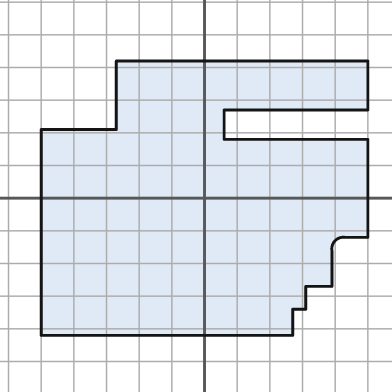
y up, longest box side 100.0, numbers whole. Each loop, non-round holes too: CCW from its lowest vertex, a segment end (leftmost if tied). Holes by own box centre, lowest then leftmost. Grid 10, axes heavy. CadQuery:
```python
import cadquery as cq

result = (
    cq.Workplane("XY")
    .moveTo(-50.0, -42.0)
    .lineTo(27.0, -42.0)
    .lineTo(27.0, -34.0)
    .lineTo(31.0, -34.0)
    .lineTo(31.0, -27.0)
    .lineTo(39.0, -27.0)
    .lineTo(39.0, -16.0)
    .threePointArc((40.0, -13.0), (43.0, -12.0))
    .lineTo(50.0, -12.0)
    .lineTo(50.0, 18.0)
    .lineTo(6.0, 18.0)
    .lineTo(6.0, 27.0)
    .lineTo(50.0, 27.0)
    .lineTo(50.0, 42.0)
    .lineTo(-27.0, 42.0)
    .lineTo(-27.0, 21.0)
    .lineTo(-50.0, 21.0)
    .close()
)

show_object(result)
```